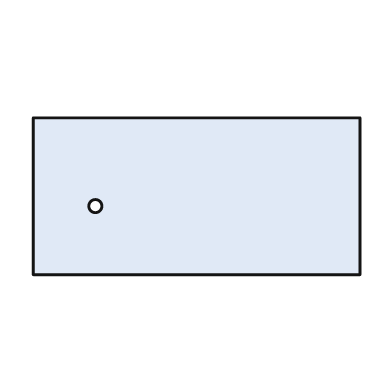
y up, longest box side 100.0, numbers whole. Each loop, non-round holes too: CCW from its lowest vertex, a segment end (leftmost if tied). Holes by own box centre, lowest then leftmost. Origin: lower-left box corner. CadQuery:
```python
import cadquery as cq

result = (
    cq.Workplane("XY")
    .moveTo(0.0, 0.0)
    .lineTo(100.0, 0.0)
    .lineTo(100.0, 48.0)
    .lineTo(0.0, 48.0)
    .close()
    .moveTo(19.0, 21.0)
    .circle(2.0)
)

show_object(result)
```